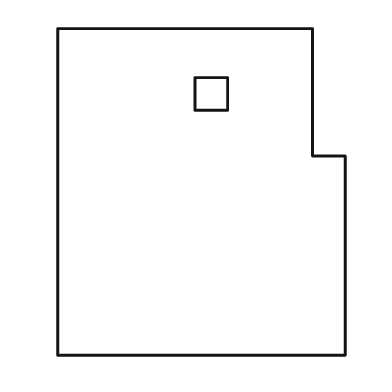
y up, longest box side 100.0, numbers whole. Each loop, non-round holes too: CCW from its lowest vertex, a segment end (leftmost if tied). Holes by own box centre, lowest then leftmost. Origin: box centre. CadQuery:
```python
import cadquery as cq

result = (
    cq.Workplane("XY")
    .moveTo(-44.0, -50.0)
    .lineTo(44.0, -50.0)
    .lineTo(44.0, 11.0)
    .lineTo(34.0, 11.0)
    .lineTo(34.0, 50.0)
    .lineTo(-44.0, 50.0)
    .close()
    .moveTo(-2.0, 25.0)
    .lineTo(8.0, 25.0)
    .lineTo(8.0, 35.0)
    .lineTo(-2.0, 35.0)
    .close()
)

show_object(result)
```